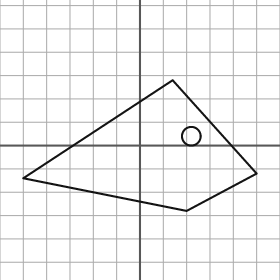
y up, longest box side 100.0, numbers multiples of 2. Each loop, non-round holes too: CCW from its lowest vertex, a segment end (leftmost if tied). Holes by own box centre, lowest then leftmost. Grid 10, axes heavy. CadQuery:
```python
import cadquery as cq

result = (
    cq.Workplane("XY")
    .moveTo(20.0, -28.0)
    .lineTo(50.0, -12.0)
    .lineTo(14.0, 28.0)
    .lineTo(-50.0, -14.0)
    .close()
    .moveTo(22.0, 4.0)
    .circle(4.0)
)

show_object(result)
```